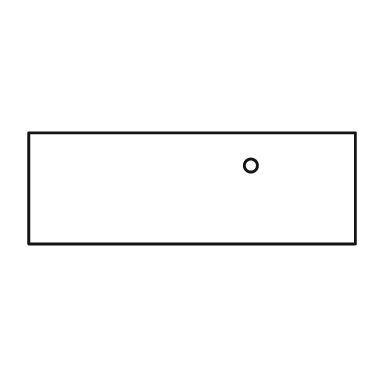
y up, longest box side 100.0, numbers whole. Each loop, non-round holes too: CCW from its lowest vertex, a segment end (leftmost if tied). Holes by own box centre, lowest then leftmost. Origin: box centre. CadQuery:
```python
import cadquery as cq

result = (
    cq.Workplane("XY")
    .moveTo(-50.0, -17.0)
    .lineTo(50.0, -17.0)
    .lineTo(50.0, 17.0)
    .lineTo(-50.0, 17.0)
    .close()
    .moveTo(18.0, 7.0)
    .circle(2.0)
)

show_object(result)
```